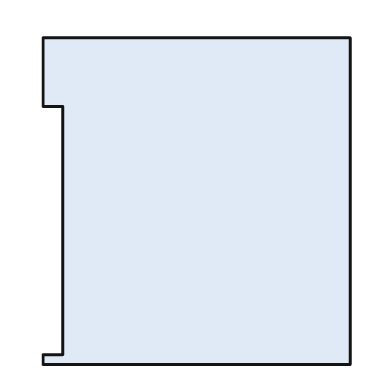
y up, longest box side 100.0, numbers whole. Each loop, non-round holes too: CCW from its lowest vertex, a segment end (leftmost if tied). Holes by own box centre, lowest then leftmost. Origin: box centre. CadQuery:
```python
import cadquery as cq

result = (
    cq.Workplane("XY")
    .moveTo(-47.0, -50.0)
    .lineTo(47.0, -50.0)
    .lineTo(47.0, 50.0)
    .lineTo(-47.0, 50.0)
    .lineTo(-47.0, 29.0)
    .lineTo(-41.0, 29.0)
    .lineTo(-41.0, -47.0)
    .lineTo(-47.0, -47.0)
    .close()
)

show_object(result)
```